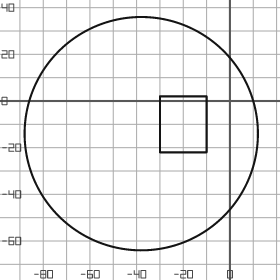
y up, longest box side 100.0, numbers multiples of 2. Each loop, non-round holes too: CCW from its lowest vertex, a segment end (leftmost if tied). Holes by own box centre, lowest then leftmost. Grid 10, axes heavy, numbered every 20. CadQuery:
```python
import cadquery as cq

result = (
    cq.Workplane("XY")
    .moveTo(-38.0, -14.0)
    .circle(50.0)
    .moveTo(-30.0, -22.0)
    .lineTo(-10.0, -22.0)
    .lineTo(-10.0, 2.0)
    .lineTo(-30.0, 2.0)
    .close()
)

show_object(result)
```